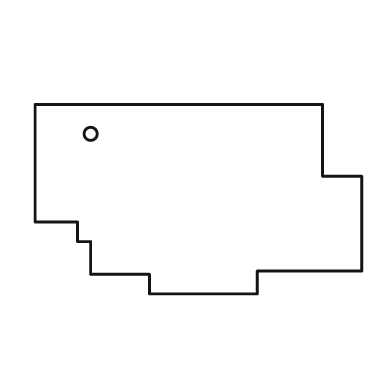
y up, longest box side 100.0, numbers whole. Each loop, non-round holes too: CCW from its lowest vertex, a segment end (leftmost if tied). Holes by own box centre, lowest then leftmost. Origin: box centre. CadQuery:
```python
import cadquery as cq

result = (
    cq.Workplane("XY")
    .moveTo(-15.0, -29.0)
    .lineTo(18.0, -29.0)
    .lineTo(18.0, -22.0)
    .lineTo(50.0, -22.0)
    .lineTo(50.0, 7.0)
    .lineTo(38.0, 7.0)
    .lineTo(38.0, 29.0)
    .lineTo(-50.0, 29.0)
    .lineTo(-50.0, -7.0)
    .lineTo(-37.0, -7.0)
    .lineTo(-37.0, -13.0)
    .lineTo(-33.0, -13.0)
    .lineTo(-33.0, -23.0)
    .lineTo(-15.0, -23.0)
    .close()
    .moveTo(-33.0, 20.0)
    .circle(2.0)
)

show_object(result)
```